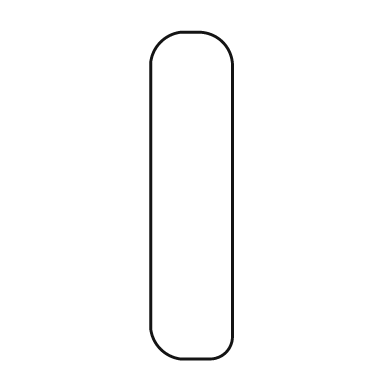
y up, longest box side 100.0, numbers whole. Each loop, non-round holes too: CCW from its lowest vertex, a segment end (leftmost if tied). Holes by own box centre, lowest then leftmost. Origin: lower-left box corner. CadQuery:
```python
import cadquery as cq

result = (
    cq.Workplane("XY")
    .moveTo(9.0, 0.0)
    .lineTo(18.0, 0.0)
    .threePointArc((23.0, 2.0), (25.0, 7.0))
    .lineTo(25.0, 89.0)
    .threePointArc((22.0, 97.0), (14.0, 100.0))
    .lineTo(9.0, 100.0)
    .threePointArc((3.0, 97.0), (0.0, 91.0))
    .lineTo(0.0, 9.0)
    .threePointArc((3.0, 3.0), (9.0, 0.0))
    .close()
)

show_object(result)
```